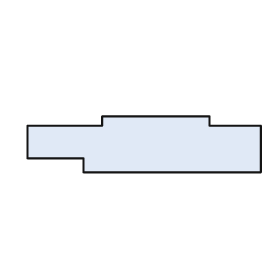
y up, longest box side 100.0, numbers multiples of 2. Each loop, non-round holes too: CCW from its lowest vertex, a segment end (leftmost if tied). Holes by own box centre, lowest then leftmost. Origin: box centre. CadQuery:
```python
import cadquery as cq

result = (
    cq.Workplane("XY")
    .moveTo(-26.0, -12.0)
    .lineTo(50.0, -12.0)
    .lineTo(50.0, 8.0)
    .lineTo(28.0, 8.0)
    .lineTo(28.0, 12.0)
    .lineTo(-18.0, 12.0)
    .lineTo(-18.0, 8.0)
    .lineTo(-50.0, 8.0)
    .lineTo(-50.0, -6.0)
    .lineTo(-26.0, -6.0)
    .close()
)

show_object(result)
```